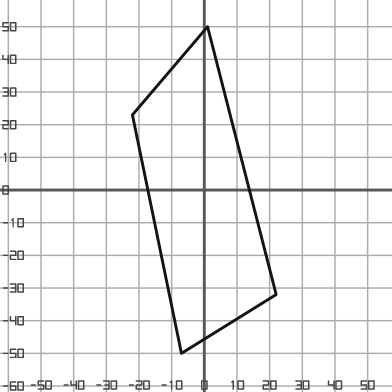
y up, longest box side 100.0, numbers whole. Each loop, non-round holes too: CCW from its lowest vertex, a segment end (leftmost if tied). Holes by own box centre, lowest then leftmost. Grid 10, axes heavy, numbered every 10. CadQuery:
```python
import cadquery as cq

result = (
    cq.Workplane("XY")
    .moveTo(-7.0, -50.0)
    .lineTo(22.0, -32.0)
    .lineTo(1.0, 50.0)
    .lineTo(-22.0, 23.0)
    .close()
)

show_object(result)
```